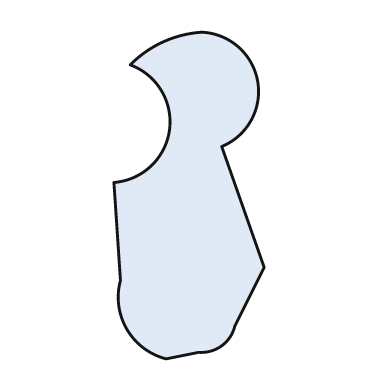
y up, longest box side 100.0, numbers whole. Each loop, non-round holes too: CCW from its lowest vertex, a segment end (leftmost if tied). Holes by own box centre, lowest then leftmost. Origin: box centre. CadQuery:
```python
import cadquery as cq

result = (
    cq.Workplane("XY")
    .moveTo(-7.0, -50.0)
    .lineTo(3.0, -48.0)
    .threePointArc((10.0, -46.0), (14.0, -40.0))
    .lineTo(23.0, -22.0)
    .lineTo(10.0, 15.0)
    .threePointArc((21.0, 35.0), (4.0, 50.0))
    .threePointArc((-8.0, 47.0), (-18.0, 40.0))
    .threePointArc((-6.0, 20.0), (-23.0, 4.0))
    .lineTo(-21.0, -26.0)
    .threePointArc((-19.0, -41.0), (-7.0, -50.0))
    .close()
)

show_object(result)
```